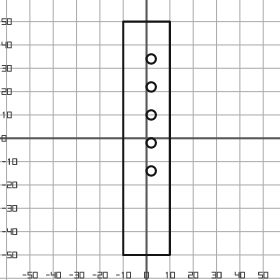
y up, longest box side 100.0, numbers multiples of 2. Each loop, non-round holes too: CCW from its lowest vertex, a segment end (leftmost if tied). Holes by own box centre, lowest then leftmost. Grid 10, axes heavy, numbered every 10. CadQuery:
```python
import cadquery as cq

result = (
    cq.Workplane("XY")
    .moveTo(-10.0, -50.0)
    .lineTo(10.0, -50.0)
    .lineTo(10.0, 50.0)
    .lineTo(-10.0, 50.0)
    .close()
    .moveTo(2.0, -14.0)
    .circle(2.0)
    .moveTo(2.0, -2.0)
    .circle(2.0)
    .moveTo(2.0, 10.0)
    .circle(2.0)
    .moveTo(2.0, 22.0)
    .circle(2.0)
    .moveTo(2.0, 34.0)
    .circle(2.0)
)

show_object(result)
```